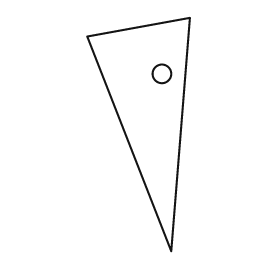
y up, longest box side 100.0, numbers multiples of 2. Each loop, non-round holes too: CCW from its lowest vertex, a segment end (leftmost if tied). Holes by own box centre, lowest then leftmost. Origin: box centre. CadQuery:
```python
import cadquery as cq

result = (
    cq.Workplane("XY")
    .moveTo(14.0, -50.0)
    .lineTo(22.0, 50.0)
    .lineTo(-22.0, 42.0)
    .close()
    .moveTo(10.0, 26.0)
    .circle(4.0)
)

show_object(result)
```